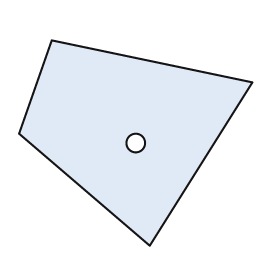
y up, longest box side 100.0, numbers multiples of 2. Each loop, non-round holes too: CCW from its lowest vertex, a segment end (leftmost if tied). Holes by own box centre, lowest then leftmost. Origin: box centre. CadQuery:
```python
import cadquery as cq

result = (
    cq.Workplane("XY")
    .moveTo(6.0, -44.0)
    .lineTo(50.0, 26.0)
    .lineTo(-36.0, 44.0)
    .lineTo(-50.0, 4.0)
    .close()
    .moveTo(0.0, 0.0)
    .circle(4.0)
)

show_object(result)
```